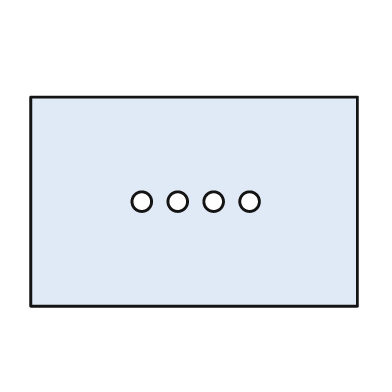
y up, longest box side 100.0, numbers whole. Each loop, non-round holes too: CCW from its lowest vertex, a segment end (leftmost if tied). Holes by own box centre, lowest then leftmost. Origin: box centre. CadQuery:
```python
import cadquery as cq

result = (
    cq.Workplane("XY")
    .moveTo(-50.0, -32.0)
    .lineTo(50.0, -32.0)
    .lineTo(50.0, 32.0)
    .lineTo(-50.0, 32.0)
    .close()
    .moveTo(-16.0, 0.0)
    .circle(3.0)
    .moveTo(-5.0, 0.0)
    .circle(3.0)
    .moveTo(6.0, 0.0)
    .circle(3.0)
    .moveTo(17.0, 0.0)
    .circle(3.0)
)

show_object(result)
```